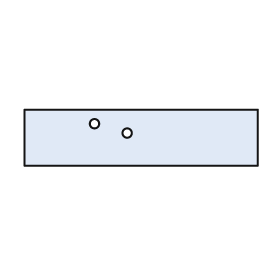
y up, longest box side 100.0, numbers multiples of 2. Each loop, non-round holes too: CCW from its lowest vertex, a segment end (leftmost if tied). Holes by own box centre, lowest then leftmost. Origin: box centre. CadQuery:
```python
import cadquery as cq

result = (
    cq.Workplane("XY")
    .moveTo(-50.0, -12.0)
    .lineTo(50.0, -12.0)
    .lineTo(50.0, 12.0)
    .lineTo(-50.0, 12.0)
    .close()
    .moveTo(-6.0, 2.0)
    .circle(2.0)
    .moveTo(-20.0, 6.0)
    .circle(2.0)
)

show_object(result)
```